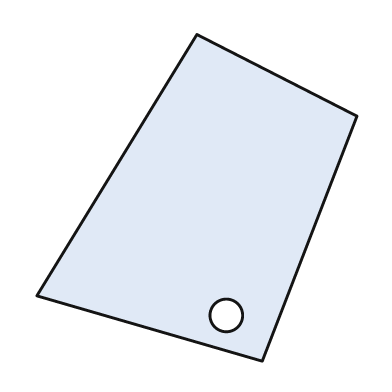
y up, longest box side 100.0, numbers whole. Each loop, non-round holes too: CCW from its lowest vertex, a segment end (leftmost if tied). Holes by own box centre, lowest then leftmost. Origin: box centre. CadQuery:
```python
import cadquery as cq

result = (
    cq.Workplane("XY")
    .moveTo(20.0, -50.0)
    .lineTo(49.0, 25.0)
    .lineTo(0.0, 50.0)
    .lineTo(-49.0, -30.0)
    .close()
    .moveTo(9.0, -36.0)
    .circle(5.0)
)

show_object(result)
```